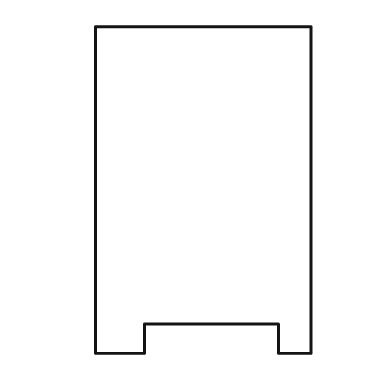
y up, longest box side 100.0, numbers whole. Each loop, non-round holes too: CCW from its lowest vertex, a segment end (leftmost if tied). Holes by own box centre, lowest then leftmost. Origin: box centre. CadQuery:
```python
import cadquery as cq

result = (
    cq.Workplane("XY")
    .moveTo(-33.0, -50.0)
    .lineTo(-18.0, -50.0)
    .lineTo(-18.0, -41.0)
    .lineTo(23.0, -41.0)
    .lineTo(23.0, -50.0)
    .lineTo(33.0, -50.0)
    .lineTo(33.0, 50.0)
    .lineTo(-33.0, 50.0)
    .close()
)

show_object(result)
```